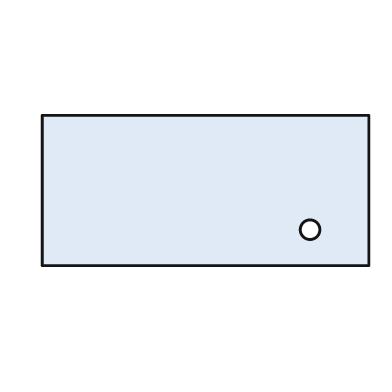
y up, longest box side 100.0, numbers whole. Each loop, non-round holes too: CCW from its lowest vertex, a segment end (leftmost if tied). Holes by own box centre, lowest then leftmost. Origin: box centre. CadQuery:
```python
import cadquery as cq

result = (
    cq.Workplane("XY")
    .moveTo(-50.0, -23.0)
    .lineTo(50.0, -23.0)
    .lineTo(50.0, 23.0)
    .lineTo(-50.0, 23.0)
    .close()
    .moveTo(32.0, -12.0)
    .circle(3.0)
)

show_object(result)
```